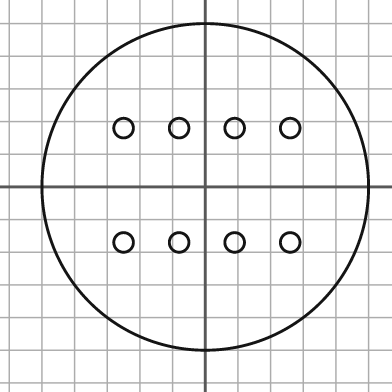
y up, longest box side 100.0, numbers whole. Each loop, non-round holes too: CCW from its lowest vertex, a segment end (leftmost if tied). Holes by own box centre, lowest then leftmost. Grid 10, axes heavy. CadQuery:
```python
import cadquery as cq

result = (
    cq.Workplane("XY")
    .moveTo(0.0, 0.0)
    .circle(50.0)
    .moveTo(-25.0, -17.0)
    .circle(3.0)
    .moveTo(-8.0, -17.0)
    .circle(3.0)
    .moveTo(9.0, -17.0)
    .circle(3.0)
    .moveTo(26.0, -17.0)
    .circle(3.0)
    .moveTo(-25.0, 18.0)
    .circle(3.0)
    .moveTo(-8.0, 18.0)
    .circle(3.0)
    .moveTo(9.0, 18.0)
    .circle(3.0)
    .moveTo(26.0, 18.0)
    .circle(3.0)
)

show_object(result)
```